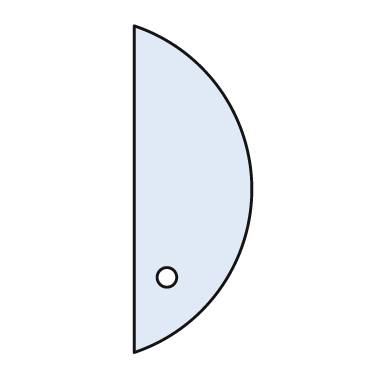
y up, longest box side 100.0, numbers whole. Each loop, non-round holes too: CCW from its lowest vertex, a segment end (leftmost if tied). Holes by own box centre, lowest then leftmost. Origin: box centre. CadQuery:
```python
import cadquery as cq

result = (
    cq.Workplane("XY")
    .moveTo(-18.0, -50.0)
    .threePointArc((18.0, 0.0), (-18.0, 50.0))
    .close()
    .moveTo(-8.0, -27.0)
    .circle(3.0)
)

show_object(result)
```